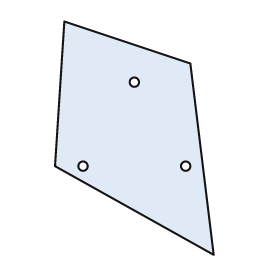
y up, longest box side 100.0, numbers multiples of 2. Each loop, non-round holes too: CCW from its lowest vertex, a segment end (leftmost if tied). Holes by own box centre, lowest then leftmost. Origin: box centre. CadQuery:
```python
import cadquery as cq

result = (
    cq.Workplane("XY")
    .moveTo(34.0, -50.0)
    .lineTo(24.0, 32.0)
    .lineTo(-30.0, 50.0)
    .lineTo(-34.0, -12.0)
    .close()
    .moveTo(-22.0, -12.0)
    .circle(2.0)
    .moveTo(22.0, -12.0)
    .circle(2.0)
    .moveTo(0.0, 24.0)
    .circle(2.0)
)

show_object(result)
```